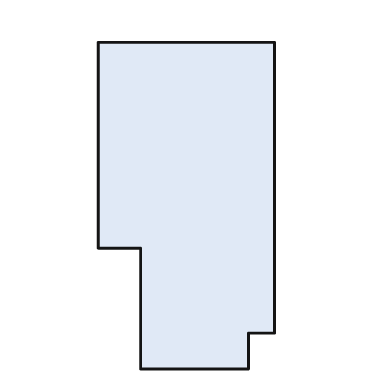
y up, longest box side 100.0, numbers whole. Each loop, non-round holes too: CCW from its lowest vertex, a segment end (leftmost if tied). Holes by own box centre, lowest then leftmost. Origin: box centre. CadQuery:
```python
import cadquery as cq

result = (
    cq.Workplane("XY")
    .moveTo(-14.0, -50.0)
    .lineTo(19.0, -50.0)
    .lineTo(19.0, -39.0)
    .lineTo(27.0, -39.0)
    .lineTo(27.0, 50.0)
    .lineTo(-27.0, 50.0)
    .lineTo(-27.0, -13.0)
    .lineTo(-14.0, -13.0)
    .close()
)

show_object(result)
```